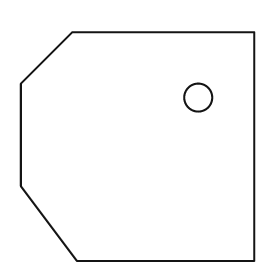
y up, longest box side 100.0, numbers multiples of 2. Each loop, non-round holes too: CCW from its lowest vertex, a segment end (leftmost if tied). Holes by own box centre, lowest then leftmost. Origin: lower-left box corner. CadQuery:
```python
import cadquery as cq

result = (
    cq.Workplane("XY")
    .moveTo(24.0, 0.0)
    .lineTo(100.0, 0.0)
    .lineTo(100.0, 98.0)
    .lineTo(22.0, 98.0)
    .lineTo(0.0, 76.0)
    .lineTo(0.0, 32.0)
    .close()
    .moveTo(76.0, 70.0)
    .circle(6.0)
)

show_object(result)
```